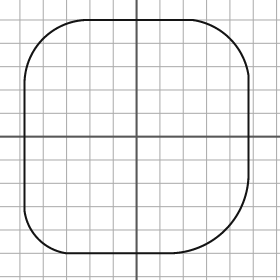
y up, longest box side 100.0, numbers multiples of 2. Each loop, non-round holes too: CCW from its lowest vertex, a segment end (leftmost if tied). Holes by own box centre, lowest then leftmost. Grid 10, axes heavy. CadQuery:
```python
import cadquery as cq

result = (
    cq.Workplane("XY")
    .moveTo(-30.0, -50.0)
    .lineTo(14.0, -50.0)
    .threePointArc((38.0, -40.0), (48.0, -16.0))
    .lineTo(48.0, 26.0)
    .threePointArc((40.0, 42.0), (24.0, 50.0))
    .lineTo(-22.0, 50.0)
    .threePointArc((-40.0, 42.0), (-48.0, 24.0))
    .lineTo(-48.0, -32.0)
    .threePointArc((-42.0, -44.0), (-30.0, -50.0))
    .close()
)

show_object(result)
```